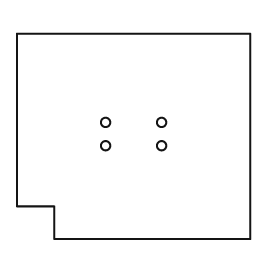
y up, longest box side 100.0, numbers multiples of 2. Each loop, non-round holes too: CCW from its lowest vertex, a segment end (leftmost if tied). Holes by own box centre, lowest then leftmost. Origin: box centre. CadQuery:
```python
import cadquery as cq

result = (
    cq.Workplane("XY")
    .moveTo(-34.0, -44.0)
    .lineTo(50.0, -44.0)
    .lineTo(50.0, 44.0)
    .lineTo(-50.0, 44.0)
    .lineTo(-50.0, -30.0)
    .lineTo(-34.0, -30.0)
    .close()
    .moveTo(-12.0, -4.0)
    .circle(2.0)
    .moveTo(12.0, -4.0)
    .circle(2.0)
    .moveTo(-12.0, 6.0)
    .circle(2.0)
    .moveTo(12.0, 6.0)
    .circle(2.0)
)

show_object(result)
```